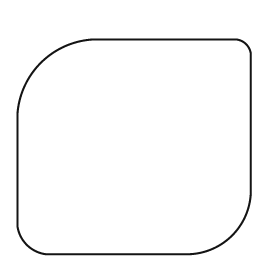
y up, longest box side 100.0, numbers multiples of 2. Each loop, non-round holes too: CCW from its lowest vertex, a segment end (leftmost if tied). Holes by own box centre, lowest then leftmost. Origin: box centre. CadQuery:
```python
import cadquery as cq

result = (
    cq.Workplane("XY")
    .moveTo(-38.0, -46.0)
    .lineTo(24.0, -46.0)
    .threePointArc((42.0, -38.0), (50.0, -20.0))
    .lineTo(50.0, 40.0)
    .threePointArc((48.0, 44.0), (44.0, 46.0))
    .lineTo(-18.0, 46.0)
    .threePointArc((-40.0, 36.0), (-50.0, 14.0))
    .lineTo(-50.0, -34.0)
    .threePointArc((-46.0, -42.0), (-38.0, -46.0))
    .close()
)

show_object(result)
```